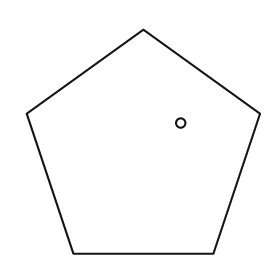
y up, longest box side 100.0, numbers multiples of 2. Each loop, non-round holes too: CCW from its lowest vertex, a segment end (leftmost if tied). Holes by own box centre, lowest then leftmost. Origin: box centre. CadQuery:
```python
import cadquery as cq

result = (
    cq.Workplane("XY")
    .moveTo(-30.0, -48.0)
    .lineTo(30.0, -48.0)
    .lineTo(50.0, 12.0)
    .lineTo(0.0, 48.0)
    .lineTo(-50.0, 12.0)
    .close()
    .moveTo(16.0, 8.0)
    .circle(2.0)
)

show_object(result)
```